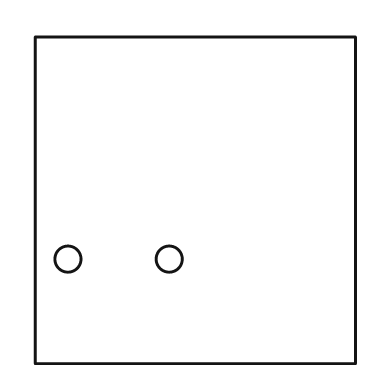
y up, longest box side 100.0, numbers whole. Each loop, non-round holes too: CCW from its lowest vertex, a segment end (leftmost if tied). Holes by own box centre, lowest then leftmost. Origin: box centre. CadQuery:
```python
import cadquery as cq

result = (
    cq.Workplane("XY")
    .moveTo(-49.0, -50.0)
    .lineTo(49.0, -50.0)
    .lineTo(49.0, 50.0)
    .lineTo(-49.0, 50.0)
    .close()
    .moveTo(-39.0, -18.0)
    .circle(4.0)
    .moveTo(-8.0, -18.0)
    .circle(4.0)
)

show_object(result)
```